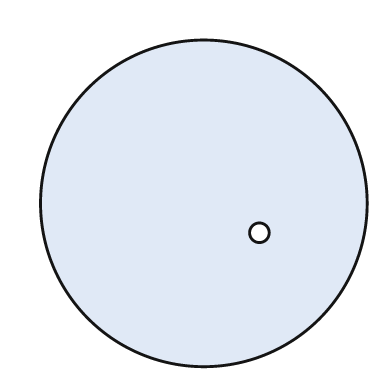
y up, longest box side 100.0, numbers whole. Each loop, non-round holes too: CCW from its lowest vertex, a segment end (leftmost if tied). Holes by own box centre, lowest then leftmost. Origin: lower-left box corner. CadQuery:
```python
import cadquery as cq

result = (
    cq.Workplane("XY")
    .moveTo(50.0, 50.0)
    .circle(50.0)
    .moveTo(67.0, 41.0)
    .circle(3.0)
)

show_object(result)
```